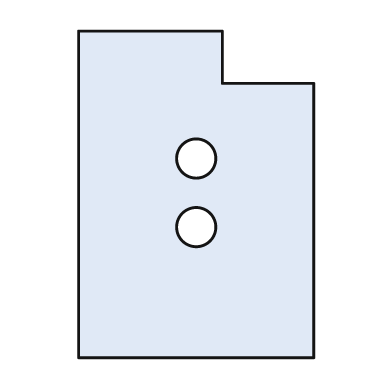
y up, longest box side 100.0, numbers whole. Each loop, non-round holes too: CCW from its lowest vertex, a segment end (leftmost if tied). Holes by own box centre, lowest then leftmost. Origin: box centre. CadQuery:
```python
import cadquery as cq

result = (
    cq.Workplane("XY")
    .moveTo(-36.0, -50.0)
    .lineTo(36.0, -50.0)
    .lineTo(36.0, 34.0)
    .lineTo(8.0, 34.0)
    .lineTo(8.0, 50.0)
    .lineTo(-36.0, 50.0)
    .close()
    .moveTo(0.0, -10.0)
    .circle(6.0)
    .moveTo(0.0, 11.0)
    .circle(6.0)
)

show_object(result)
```